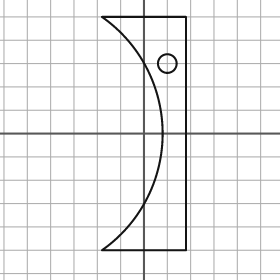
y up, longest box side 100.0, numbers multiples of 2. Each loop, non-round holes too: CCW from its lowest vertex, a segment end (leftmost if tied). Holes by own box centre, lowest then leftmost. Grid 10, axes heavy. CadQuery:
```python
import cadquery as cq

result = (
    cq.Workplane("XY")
    .moveTo(-18.0, -50.0)
    .lineTo(18.0, -50.0)
    .lineTo(18.0, 50.0)
    .lineTo(-18.0, 50.0)
    .threePointArc((8.0, 0.0), (-18.0, -50.0))
    .close()
    .moveTo(10.0, 30.0)
    .circle(4.0)
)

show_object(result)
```